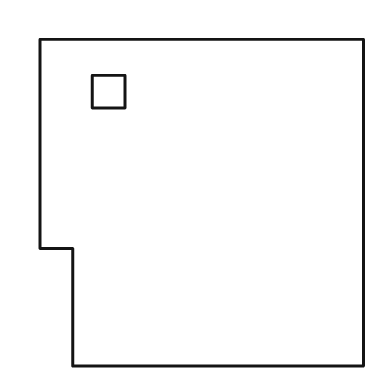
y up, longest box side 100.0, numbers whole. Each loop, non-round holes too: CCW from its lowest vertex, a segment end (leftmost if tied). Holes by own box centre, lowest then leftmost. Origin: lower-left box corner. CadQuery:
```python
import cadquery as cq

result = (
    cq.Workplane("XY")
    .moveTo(10.0, 0.0)
    .lineTo(99.0, 0.0)
    .lineTo(99.0, 100.0)
    .lineTo(0.0, 100.0)
    .lineTo(0.0, 36.0)
    .lineTo(10.0, 36.0)
    .close()
    .moveTo(16.0, 79.0)
    .lineTo(26.0, 79.0)
    .lineTo(26.0, 89.0)
    .lineTo(16.0, 89.0)
    .close()
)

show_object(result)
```